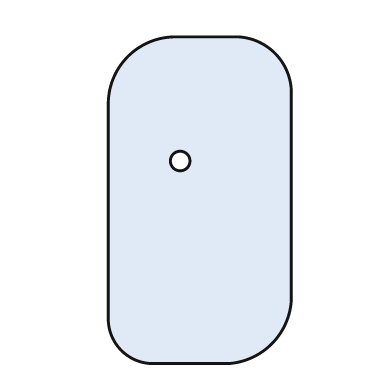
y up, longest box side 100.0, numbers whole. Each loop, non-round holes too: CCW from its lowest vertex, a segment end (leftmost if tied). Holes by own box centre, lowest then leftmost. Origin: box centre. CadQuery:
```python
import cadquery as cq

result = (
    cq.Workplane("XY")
    .moveTo(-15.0, -50.0)
    .lineTo(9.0, -50.0)
    .threePointArc((22.0, -44.0), (28.0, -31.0))
    .lineTo(28.0, 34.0)
    .threePointArc((23.0, 45.0), (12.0, 50.0))
    .lineTo(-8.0, 50.0)
    .threePointArc((-22.0, 44.0), (-28.0, 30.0))
    .lineTo(-28.0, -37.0)
    .threePointArc((-24.0, -46.0), (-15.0, -50.0))
    .close()
    .moveTo(-6.0, 12.0)
    .circle(3.0)
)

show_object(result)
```